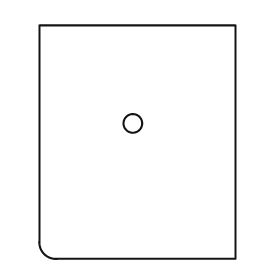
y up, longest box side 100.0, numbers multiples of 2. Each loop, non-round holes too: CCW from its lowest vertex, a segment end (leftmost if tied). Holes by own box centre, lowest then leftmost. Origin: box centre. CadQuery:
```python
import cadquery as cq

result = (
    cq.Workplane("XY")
    .moveTo(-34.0, -50.0)
    .lineTo(42.0, -50.0)
    .lineTo(42.0, 50.0)
    .lineTo(-42.0, 50.0)
    .lineTo(-42.0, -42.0)
    .threePointArc((-40.0, -48.0), (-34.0, -50.0))
    .close()
    .moveTo(-2.0, 8.0)
    .circle(4.0)
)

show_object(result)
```